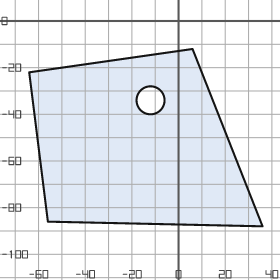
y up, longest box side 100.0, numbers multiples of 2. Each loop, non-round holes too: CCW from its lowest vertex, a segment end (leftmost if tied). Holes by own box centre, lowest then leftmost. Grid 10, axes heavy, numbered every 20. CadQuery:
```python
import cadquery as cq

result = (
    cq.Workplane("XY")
    .moveTo(36.0, -88.0)
    .lineTo(6.0, -12.0)
    .lineTo(-64.0, -22.0)
    .lineTo(-56.0, -86.0)
    .close()
    .moveTo(-12.0, -34.0)
    .circle(6.0)
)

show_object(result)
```